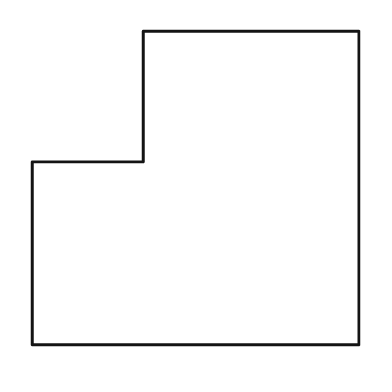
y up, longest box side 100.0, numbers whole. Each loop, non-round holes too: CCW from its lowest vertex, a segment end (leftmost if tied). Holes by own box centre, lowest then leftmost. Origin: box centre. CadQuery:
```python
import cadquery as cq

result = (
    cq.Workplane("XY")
    .moveTo(-50.0, -48.0)
    .lineTo(50.0, -48.0)
    .lineTo(50.0, 48.0)
    .lineTo(-16.0, 48.0)
    .lineTo(-16.0, 8.0)
    .lineTo(-50.0, 8.0)
    .close()
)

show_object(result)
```